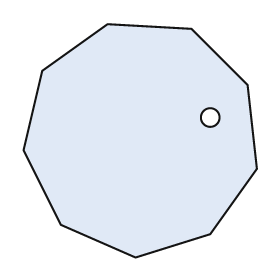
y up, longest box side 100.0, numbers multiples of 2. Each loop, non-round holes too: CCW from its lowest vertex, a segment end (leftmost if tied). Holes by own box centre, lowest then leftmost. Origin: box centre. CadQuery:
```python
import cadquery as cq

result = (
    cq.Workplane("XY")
    .moveTo(-2.0, -50.0)
    .lineTo(30.0, -40.0)
    .lineTo(50.0, -12.0)
    .lineTo(46.0, 24.0)
    .lineTo(22.0, 48.0)
    .lineTo(-14.0, 50.0)
    .lineTo(-42.0, 30.0)
    .lineTo(-50.0, -4.0)
    .lineTo(-34.0, -36.0)
    .close()
    .moveTo(30.0, 10.0)
    .circle(4.0)
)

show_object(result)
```